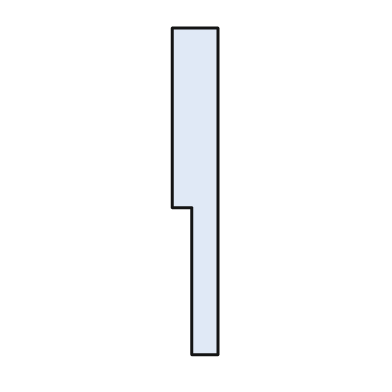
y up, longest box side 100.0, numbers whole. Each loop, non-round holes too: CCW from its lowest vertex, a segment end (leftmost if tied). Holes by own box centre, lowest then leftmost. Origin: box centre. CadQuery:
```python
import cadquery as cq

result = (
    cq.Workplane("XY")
    .moveTo(-1.0, -50.0)
    .lineTo(7.0, -50.0)
    .lineTo(7.0, 50.0)
    .lineTo(-7.0, 50.0)
    .lineTo(-7.0, -5.0)
    .lineTo(-1.0, -5.0)
    .close()
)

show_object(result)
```